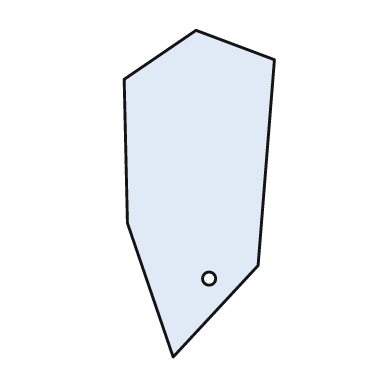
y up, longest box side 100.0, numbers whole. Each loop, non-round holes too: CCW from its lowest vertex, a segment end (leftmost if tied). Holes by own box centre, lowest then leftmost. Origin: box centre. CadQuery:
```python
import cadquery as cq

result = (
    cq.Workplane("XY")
    .moveTo(-8.0, -50.0)
    .lineTo(18.0, -22.0)
    .lineTo(23.0, 41.0)
    .lineTo(-1.0, 50.0)
    .lineTo(-23.0, 35.0)
    .lineTo(-22.0, -9.0)
    .close()
    .moveTo(3.0, -26.0)
    .circle(2.0)
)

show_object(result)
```